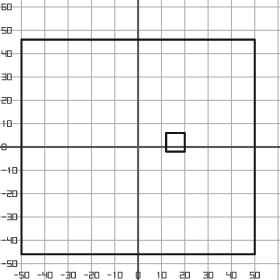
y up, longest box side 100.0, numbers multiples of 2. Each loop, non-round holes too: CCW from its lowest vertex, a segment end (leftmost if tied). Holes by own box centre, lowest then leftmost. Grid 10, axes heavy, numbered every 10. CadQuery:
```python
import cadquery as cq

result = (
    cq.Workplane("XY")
    .moveTo(-50.0, -46.0)
    .lineTo(50.0, -46.0)
    .lineTo(50.0, 46.0)
    .lineTo(-50.0, 46.0)
    .close()
    .moveTo(12.0, -2.0)
    .lineTo(20.0, -2.0)
    .lineTo(20.0, 6.0)
    .lineTo(12.0, 6.0)
    .close()
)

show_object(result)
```